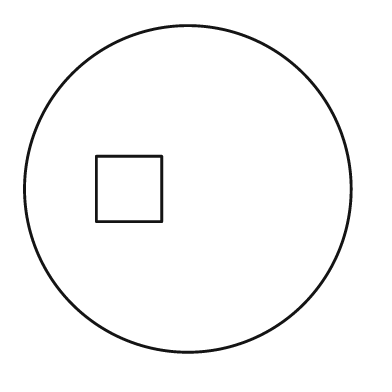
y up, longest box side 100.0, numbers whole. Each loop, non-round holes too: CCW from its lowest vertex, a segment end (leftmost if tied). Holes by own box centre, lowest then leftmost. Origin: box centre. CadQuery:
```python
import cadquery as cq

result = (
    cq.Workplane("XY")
    .moveTo(0.0, 0.0)
    .circle(50.0)
    .moveTo(-28.0, -10.0)
    .lineTo(-8.0, -10.0)
    .lineTo(-8.0, 10.0)
    .lineTo(-28.0, 10.0)
    .close()
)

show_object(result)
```